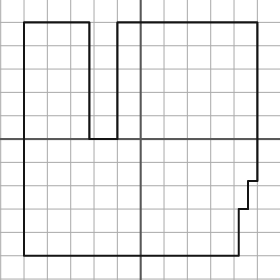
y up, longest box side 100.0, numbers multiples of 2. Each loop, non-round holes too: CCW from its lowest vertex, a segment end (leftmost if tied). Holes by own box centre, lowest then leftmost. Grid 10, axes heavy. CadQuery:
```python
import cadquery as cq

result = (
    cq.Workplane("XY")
    .moveTo(-50.0, -50.0)
    .lineTo(42.0, -50.0)
    .lineTo(42.0, -30.0)
    .lineTo(46.0, -30.0)
    .lineTo(46.0, -18.0)
    .lineTo(50.0, -18.0)
    .lineTo(50.0, 50.0)
    .lineTo(-10.0, 50.0)
    .lineTo(-10.0, 0.0)
    .lineTo(-22.0, 0.0)
    .lineTo(-22.0, 50.0)
    .lineTo(-50.0, 50.0)
    .close()
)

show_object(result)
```